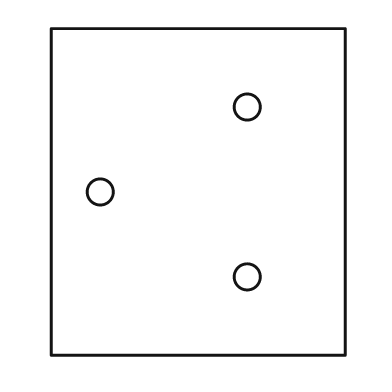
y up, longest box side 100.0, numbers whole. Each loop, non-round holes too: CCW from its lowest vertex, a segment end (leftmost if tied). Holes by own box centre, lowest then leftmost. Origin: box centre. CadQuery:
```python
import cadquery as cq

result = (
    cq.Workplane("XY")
    .moveTo(-45.0, -50.0)
    .lineTo(45.0, -50.0)
    .lineTo(45.0, 50.0)
    .lineTo(-45.0, 50.0)
    .close()
    .moveTo(15.0, -26.0)
    .circle(4.0)
    .moveTo(-30.0, 0.0)
    .circle(4.0)
    .moveTo(15.0, 26.0)
    .circle(4.0)
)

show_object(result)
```